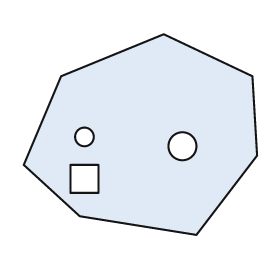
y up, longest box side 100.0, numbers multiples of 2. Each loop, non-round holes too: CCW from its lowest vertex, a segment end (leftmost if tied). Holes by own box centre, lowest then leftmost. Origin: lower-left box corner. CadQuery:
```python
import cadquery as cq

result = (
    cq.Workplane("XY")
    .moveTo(74.0, 0.0)
    .lineTo(100.0, 34.0)
    .lineTo(98.0, 68.0)
    .lineTo(60.0, 86.0)
    .lineTo(16.0, 68.0)
    .lineTo(0.0, 30.0)
    .lineTo(24.0, 8.0)
    .close()
    .moveTo(20.0, 18.0)
    .lineTo(32.0, 18.0)
    .lineTo(32.0, 30.0)
    .lineTo(20.0, 30.0)
    .close()
    .moveTo(68.0, 38.0)
    .circle(6.0)
    .moveTo(26.0, 42.0)
    .circle(4.0)
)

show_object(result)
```